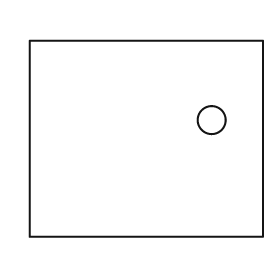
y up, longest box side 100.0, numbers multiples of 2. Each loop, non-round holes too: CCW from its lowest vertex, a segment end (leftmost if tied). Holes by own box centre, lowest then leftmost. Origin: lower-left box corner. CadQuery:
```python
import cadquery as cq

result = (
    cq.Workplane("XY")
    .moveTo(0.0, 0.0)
    .lineTo(100.0, 0.0)
    .lineTo(100.0, 84.0)
    .lineTo(0.0, 84.0)
    .close()
    .moveTo(78.0, 50.0)
    .circle(6.0)
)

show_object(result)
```